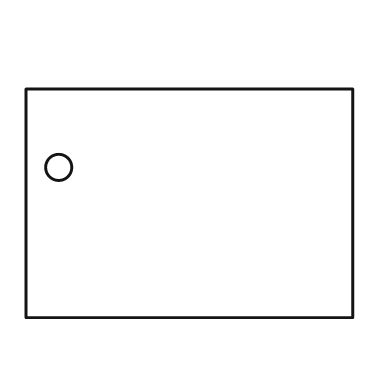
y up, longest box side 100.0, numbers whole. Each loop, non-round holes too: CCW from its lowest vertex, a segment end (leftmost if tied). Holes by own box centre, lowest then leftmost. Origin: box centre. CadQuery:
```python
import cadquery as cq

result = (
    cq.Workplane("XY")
    .moveTo(-50.0, -35.0)
    .lineTo(50.0, -35.0)
    .lineTo(50.0, 35.0)
    .lineTo(-50.0, 35.0)
    .close()
    .moveTo(-40.0, 11.0)
    .circle(4.0)
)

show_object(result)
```